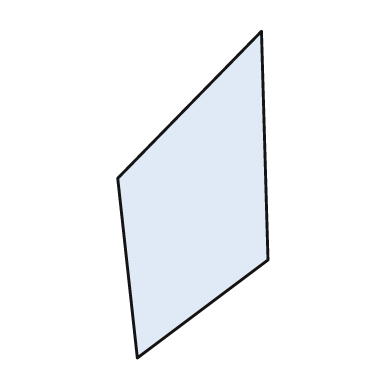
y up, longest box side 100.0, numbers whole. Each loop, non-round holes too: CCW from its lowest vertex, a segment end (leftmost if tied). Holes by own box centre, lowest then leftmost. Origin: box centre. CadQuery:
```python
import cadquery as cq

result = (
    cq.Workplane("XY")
    .moveTo(-17.0, -50.0)
    .lineTo(23.0, -20.0)
    .lineTo(21.0, 50.0)
    .lineTo(-23.0, 5.0)
    .close()
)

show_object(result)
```